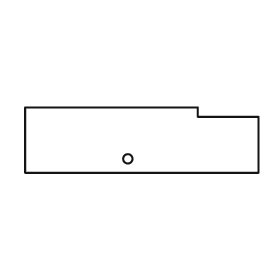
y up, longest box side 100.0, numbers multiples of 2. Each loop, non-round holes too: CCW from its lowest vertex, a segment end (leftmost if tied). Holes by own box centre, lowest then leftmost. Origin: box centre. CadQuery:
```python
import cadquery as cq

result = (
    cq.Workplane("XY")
    .moveTo(-50.0, -14.0)
    .lineTo(50.0, -14.0)
    .lineTo(50.0, 10.0)
    .lineTo(24.0, 10.0)
    .lineTo(24.0, 14.0)
    .lineTo(-50.0, 14.0)
    .close()
    .moveTo(-6.0, -8.0)
    .circle(2.0)
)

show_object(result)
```